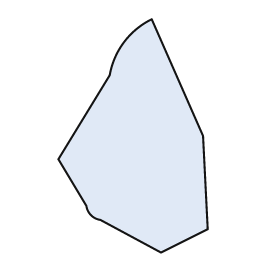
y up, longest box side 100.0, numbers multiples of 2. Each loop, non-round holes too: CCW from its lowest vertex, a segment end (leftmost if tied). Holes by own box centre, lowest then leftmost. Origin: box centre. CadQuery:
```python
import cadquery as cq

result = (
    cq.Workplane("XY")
    .moveTo(12.0, -50.0)
    .lineTo(32.0, -40.0)
    .lineTo(30.0, 0.0)
    .lineTo(8.0, 50.0)
    .threePointArc((-4.0, 40.0), (-10.0, 26.0))
    .lineTo(-32.0, -10.0)
    .lineTo(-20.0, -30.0)
    .threePointArc((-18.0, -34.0), (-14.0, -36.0))
    .close()
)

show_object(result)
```